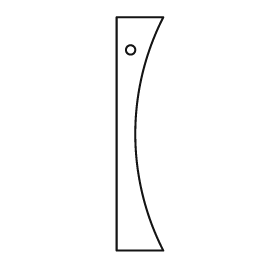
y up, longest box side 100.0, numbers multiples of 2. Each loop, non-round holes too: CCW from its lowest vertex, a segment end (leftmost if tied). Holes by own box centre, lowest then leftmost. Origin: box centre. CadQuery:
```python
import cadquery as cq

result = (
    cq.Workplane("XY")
    .moveTo(-10.0, -50.0)
    .lineTo(10.0, -50.0)
    .threePointArc((-2.0, 0.0), (10.0, 50.0))
    .lineTo(-10.0, 50.0)
    .close()
    .moveTo(-4.0, 36.0)
    .circle(2.0)
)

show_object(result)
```